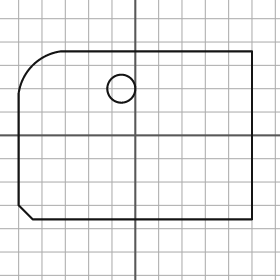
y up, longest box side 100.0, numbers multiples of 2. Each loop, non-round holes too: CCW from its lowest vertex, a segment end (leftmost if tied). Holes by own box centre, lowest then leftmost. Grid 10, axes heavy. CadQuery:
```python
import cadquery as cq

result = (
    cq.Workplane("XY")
    .moveTo(-44.0, -36.0)
    .lineTo(50.0, -36.0)
    .lineTo(50.0, 36.0)
    .lineTo(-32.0, 36.0)
    .threePointArc((-44.0, 30.0), (-50.0, 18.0))
    .lineTo(-50.0, -30.0)
    .close()
    .moveTo(-6.0, 20.0)
    .circle(6.0)
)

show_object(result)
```